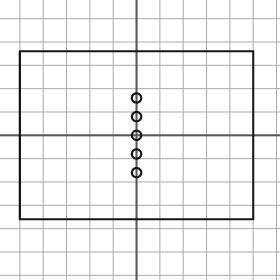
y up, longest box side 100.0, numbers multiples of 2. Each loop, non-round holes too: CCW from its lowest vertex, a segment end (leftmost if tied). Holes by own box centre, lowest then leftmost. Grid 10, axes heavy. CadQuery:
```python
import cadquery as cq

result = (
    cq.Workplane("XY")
    .moveTo(-50.0, -36.0)
    .lineTo(50.0, -36.0)
    .lineTo(50.0, 36.0)
    .lineTo(-50.0, 36.0)
    .close()
    .moveTo(0.0, -16.0)
    .circle(2.0)
    .moveTo(0.0, -8.0)
    .circle(2.0)
    .moveTo(0.0, 0.0)
    .circle(2.0)
    .moveTo(0.0, 8.0)
    .circle(2.0)
    .moveTo(0.0, 16.0)
    .circle(2.0)
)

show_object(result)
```